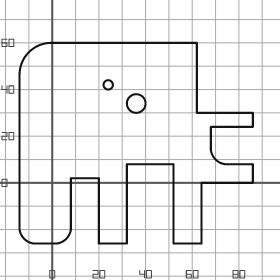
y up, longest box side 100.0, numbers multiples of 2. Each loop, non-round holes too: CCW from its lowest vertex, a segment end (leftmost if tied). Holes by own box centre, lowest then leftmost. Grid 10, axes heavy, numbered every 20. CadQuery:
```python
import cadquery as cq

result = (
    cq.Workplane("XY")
    .moveTo(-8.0, -26.0)
    .lineTo(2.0, -26.0)
    .threePointArc((6.0, -24.0), (8.0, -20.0))
    .lineTo(8.0, 2.0)
    .lineTo(20.0, 2.0)
    .lineTo(20.0, -26.0)
    .lineTo(32.0, -26.0)
    .lineTo(32.0, 8.0)
    .lineTo(52.0, 8.0)
    .lineTo(52.0, -26.0)
    .lineTo(64.0, -26.0)
    .lineTo(64.0, 0.0)
    .lineTo(86.0, 0.0)
    .lineTo(86.0, 8.0)
    .lineTo(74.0, 8.0)
    .threePointArc((70.0, 10.0), (68.0, 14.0))
    .lineTo(68.0, 24.0)
    .lineTo(86.0, 24.0)
    .lineTo(86.0, 30.0)
    .lineTo(62.0, 30.0)
    .lineTo(62.0, 60.0)
    .lineTo(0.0, 60.0)
    .threePointArc((-10.0, 56.0), (-14.0, 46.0))
    .lineTo(-14.0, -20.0)
    .threePointArc((-12.0, -24.0), (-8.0, -26.0))
    .close()
    .moveTo(36.0, 34.0)
    .circle(4.0)
    .moveTo(24.0, 42.0)
    .circle(2.0)
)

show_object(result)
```